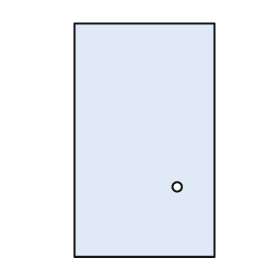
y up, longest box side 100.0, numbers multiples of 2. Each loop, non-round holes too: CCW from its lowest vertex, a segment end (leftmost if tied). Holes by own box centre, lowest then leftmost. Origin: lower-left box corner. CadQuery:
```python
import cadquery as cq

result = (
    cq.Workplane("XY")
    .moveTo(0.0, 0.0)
    .lineTo(60.0, 0.0)
    .lineTo(60.0, 100.0)
    .lineTo(0.0, 100.0)
    .close()
    .moveTo(44.0, 30.0)
    .circle(2.0)
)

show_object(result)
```